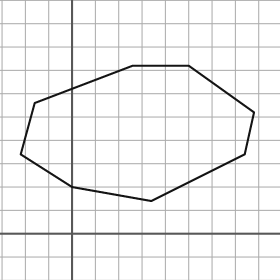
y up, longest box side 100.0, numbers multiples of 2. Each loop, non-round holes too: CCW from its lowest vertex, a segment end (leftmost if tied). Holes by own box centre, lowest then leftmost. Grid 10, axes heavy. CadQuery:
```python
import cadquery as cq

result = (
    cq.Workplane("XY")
    .moveTo(34.0, 14.0)
    .lineTo(74.0, 34.0)
    .lineTo(78.0, 52.0)
    .lineTo(50.0, 72.0)
    .lineTo(26.0, 72.0)
    .lineTo(-16.0, 56.0)
    .lineTo(-22.0, 34.0)
    .lineTo(0.0, 20.0)
    .close()
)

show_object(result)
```